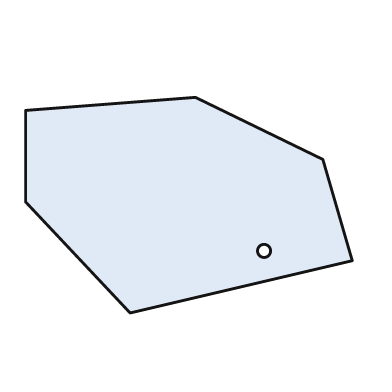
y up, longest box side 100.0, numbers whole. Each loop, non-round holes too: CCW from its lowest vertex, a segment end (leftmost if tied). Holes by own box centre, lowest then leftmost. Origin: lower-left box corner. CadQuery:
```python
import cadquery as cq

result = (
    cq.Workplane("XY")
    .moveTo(32.0, 0.0)
    .lineTo(100.0, 16.0)
    .lineTo(91.0, 47.0)
    .lineTo(52.0, 66.0)
    .lineTo(0.0, 62.0)
    .lineTo(0.0, 34.0)
    .close()
    .moveTo(73.0, 19.0)
    .circle(2.0)
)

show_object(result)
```